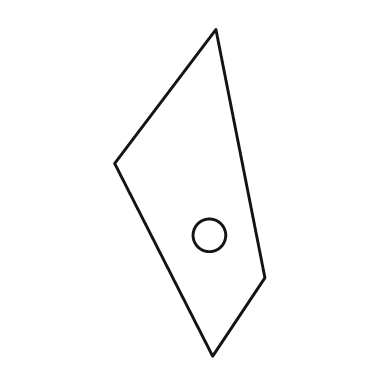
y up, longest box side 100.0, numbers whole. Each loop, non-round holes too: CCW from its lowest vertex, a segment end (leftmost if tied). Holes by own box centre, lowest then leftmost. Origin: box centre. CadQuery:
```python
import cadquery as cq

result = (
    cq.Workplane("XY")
    .moveTo(7.0, -50.0)
    .lineTo(23.0, -26.0)
    .lineTo(8.0, 50.0)
    .lineTo(-23.0, 9.0)
    .close()
    .moveTo(6.0, -13.0)
    .circle(5.0)
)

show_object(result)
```